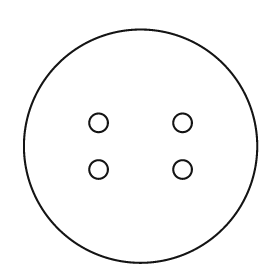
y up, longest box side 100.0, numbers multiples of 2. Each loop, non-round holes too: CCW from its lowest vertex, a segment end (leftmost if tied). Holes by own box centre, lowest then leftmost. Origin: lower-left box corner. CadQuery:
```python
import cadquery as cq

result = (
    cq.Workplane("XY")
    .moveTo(50.0, 50.0)
    .circle(50.0)
    .moveTo(32.0, 40.0)
    .circle(4.0)
    .moveTo(68.0, 40.0)
    .circle(4.0)
    .moveTo(32.0, 60.0)
    .circle(4.0)
    .moveTo(68.0, 60.0)
    .circle(4.0)
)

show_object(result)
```